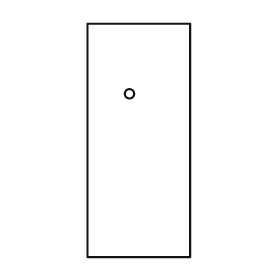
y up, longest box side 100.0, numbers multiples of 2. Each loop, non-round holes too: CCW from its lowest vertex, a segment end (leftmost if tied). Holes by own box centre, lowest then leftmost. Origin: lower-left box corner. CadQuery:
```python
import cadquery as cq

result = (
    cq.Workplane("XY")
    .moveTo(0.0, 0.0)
    .lineTo(44.0, 0.0)
    .lineTo(44.0, 100.0)
    .lineTo(0.0, 100.0)
    .close()
    .moveTo(18.0, 70.0)
    .circle(2.0)
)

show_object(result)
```